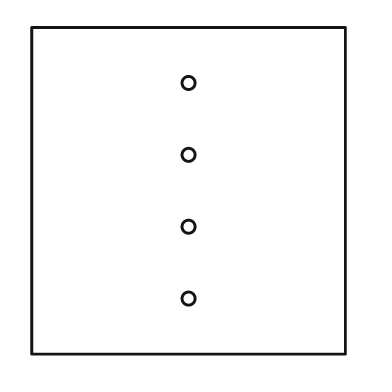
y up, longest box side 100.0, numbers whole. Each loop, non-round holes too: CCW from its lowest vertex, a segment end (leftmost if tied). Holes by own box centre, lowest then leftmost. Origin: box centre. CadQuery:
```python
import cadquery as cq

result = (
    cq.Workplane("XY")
    .moveTo(-48.0, -50.0)
    .lineTo(48.0, -50.0)
    .lineTo(48.0, 50.0)
    .lineTo(-48.0, 50.0)
    .close()
    .moveTo(0.0, -33.0)
    .circle(2.0)
    .moveTo(0.0, -11.0)
    .circle(2.0)
    .moveTo(0.0, 11.0)
    .circle(2.0)
    .moveTo(0.0, 33.0)
    .circle(2.0)
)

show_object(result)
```